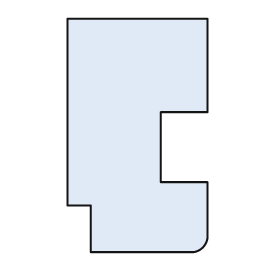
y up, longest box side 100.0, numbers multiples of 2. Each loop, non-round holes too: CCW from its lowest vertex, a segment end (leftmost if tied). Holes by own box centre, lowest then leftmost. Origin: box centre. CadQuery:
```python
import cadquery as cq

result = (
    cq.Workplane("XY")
    .moveTo(-20.0, -50.0)
    .lineTo(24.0, -50.0)
    .threePointArc((28.0, -48.0), (30.0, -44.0))
    .lineTo(30.0, -20.0)
    .lineTo(10.0, -20.0)
    .lineTo(10.0, 10.0)
    .lineTo(30.0, 10.0)
    .lineTo(30.0, 50.0)
    .lineTo(-30.0, 50.0)
    .lineTo(-30.0, -30.0)
    .lineTo(-20.0, -30.0)
    .close()
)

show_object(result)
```